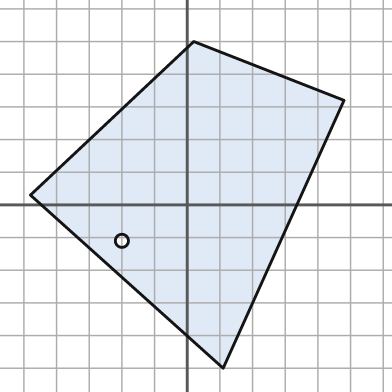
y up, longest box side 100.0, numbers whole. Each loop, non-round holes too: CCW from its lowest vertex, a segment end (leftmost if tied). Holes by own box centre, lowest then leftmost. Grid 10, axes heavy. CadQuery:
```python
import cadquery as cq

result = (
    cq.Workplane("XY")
    .moveTo(11.0, -50.0)
    .lineTo(48.0, 32.0)
    .lineTo(2.0, 50.0)
    .lineTo(-48.0, 3.0)
    .close()
    .moveTo(-20.0, -11.0)
    .circle(2.0)
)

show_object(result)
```